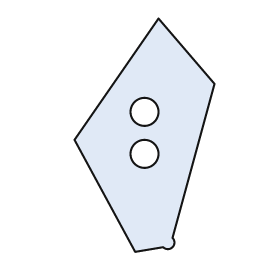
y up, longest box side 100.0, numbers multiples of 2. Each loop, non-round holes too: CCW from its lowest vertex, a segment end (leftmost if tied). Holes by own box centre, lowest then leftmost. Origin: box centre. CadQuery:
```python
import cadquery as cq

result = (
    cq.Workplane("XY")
    .moveTo(-4.0, -50.0)
    .lineTo(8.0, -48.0)
    .threePointArc((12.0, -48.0), (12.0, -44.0))
    .lineTo(30.0, 22.0)
    .lineTo(6.0, 50.0)
    .lineTo(-30.0, -2.0)
    .close()
    .moveTo(0.0, -8.0)
    .circle(6.0)
    .moveTo(0.0, 10.0)
    .circle(6.0)
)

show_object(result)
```